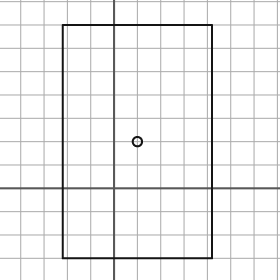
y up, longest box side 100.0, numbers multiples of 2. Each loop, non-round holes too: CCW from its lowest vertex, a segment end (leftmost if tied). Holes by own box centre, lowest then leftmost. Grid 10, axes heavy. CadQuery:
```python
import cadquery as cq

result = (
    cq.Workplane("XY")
    .moveTo(-22.0, -30.0)
    .lineTo(42.0, -30.0)
    .lineTo(42.0, 70.0)
    .lineTo(-22.0, 70.0)
    .close()
    .moveTo(10.0, 20.0)
    .circle(2.0)
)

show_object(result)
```